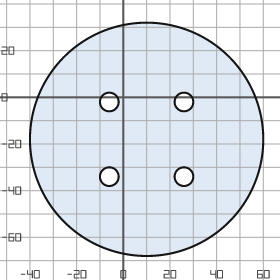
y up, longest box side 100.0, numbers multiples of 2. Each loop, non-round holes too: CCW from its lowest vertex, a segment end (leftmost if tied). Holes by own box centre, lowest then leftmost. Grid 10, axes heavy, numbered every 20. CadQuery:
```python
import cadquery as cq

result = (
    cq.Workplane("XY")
    .moveTo(10.0, -18.0)
    .circle(50.0)
    .moveTo(-6.0, -34.0)
    .circle(4.0)
    .moveTo(26.0, -34.0)
    .circle(4.0)
    .moveTo(-6.0, -2.0)
    .circle(4.0)
    .moveTo(26.0, -2.0)
    .circle(4.0)
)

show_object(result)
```